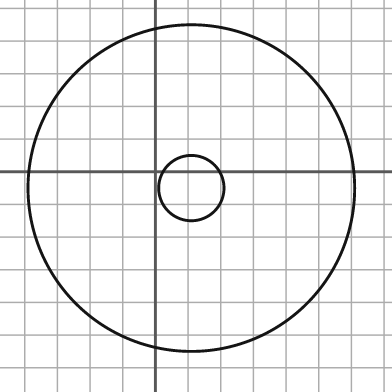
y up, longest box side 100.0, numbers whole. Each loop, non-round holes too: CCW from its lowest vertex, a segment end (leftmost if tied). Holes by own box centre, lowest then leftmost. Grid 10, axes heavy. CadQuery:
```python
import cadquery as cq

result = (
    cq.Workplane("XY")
    .moveTo(11.0, -5.0)
    .circle(50.0)
    .moveTo(11.0, -5.0)
    .circle(10.0)
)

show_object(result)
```